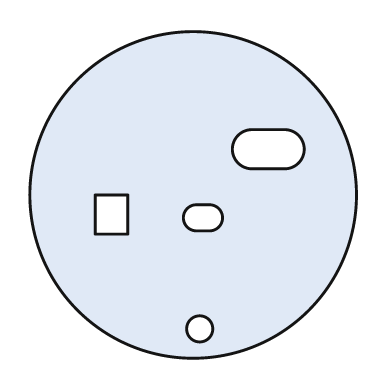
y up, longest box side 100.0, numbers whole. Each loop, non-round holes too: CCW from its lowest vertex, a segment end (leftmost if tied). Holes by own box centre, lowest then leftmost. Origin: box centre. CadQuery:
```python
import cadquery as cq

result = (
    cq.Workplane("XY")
    .moveTo(0.0, 0.0)
    .circle(50.0)
    .moveTo(2.0, -41.0)
    .circle(4.0)
    .moveTo(1.0, -11.0)
    .lineTo(5.0, -11.0)
    .threePointArc((9.0, -7.0), (5.0, -3.0))
    .lineTo(1.0, -3.0)
    .threePointArc((-3.0, -7.0), (1.0, -11.0))
    .close()
    .moveTo(-30.0, -12.0)
    .lineTo(-20.0, -12.0)
    .lineTo(-20.0, 0.0)
    .lineTo(-30.0, 0.0)
    .close()
    .moveTo(18.0, 8.0)
    .lineTo(28.0, 8.0)
    .threePointArc((34.0, 14.0), (28.0, 20.0))
    .lineTo(18.0, 20.0)
    .threePointArc((12.0, 14.0), (18.0, 8.0))
    .close()
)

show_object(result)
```